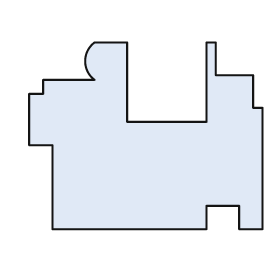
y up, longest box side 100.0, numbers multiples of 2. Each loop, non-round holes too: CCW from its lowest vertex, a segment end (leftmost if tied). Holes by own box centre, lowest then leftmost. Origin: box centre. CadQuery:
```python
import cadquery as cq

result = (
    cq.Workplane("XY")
    .moveTo(-40.0, -40.0)
    .lineTo(26.0, -40.0)
    .lineTo(26.0, -30.0)
    .lineTo(40.0, -30.0)
    .lineTo(40.0, -40.0)
    .lineTo(50.0, -40.0)
    .lineTo(50.0, 12.0)
    .lineTo(46.0, 12.0)
    .lineTo(46.0, 26.0)
    .lineTo(30.0, 26.0)
    .lineTo(30.0, 40.0)
    .lineTo(26.0, 40.0)
    .lineTo(26.0, 6.0)
    .lineTo(-8.0, 6.0)
    .lineTo(-8.0, 40.0)
    .lineTo(-22.0, 40.0)
    .threePointArc((-26.0, 32.0), (-22.0, 24.0))
    .lineTo(-44.0, 24.0)
    .lineTo(-44.0, 18.0)
    .lineTo(-50.0, 18.0)
    .lineTo(-50.0, -4.0)
    .lineTo(-40.0, -4.0)
    .close()
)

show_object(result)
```